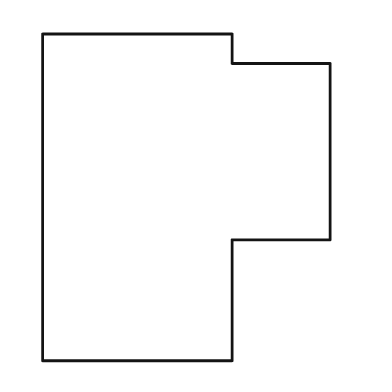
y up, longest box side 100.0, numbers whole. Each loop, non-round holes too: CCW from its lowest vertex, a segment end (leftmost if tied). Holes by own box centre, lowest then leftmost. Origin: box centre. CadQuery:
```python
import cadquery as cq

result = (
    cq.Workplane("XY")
    .moveTo(-44.0, -50.0)
    .lineTo(14.0, -50.0)
    .lineTo(14.0, -13.0)
    .lineTo(44.0, -13.0)
    .lineTo(44.0, 41.0)
    .lineTo(14.0, 41.0)
    .lineTo(14.0, 50.0)
    .lineTo(-44.0, 50.0)
    .close()
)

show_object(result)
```